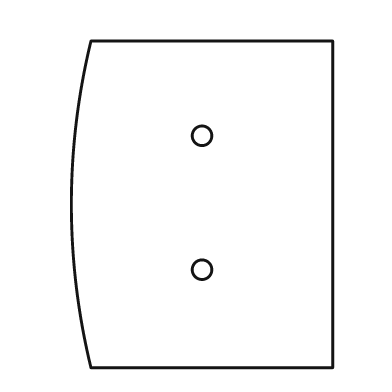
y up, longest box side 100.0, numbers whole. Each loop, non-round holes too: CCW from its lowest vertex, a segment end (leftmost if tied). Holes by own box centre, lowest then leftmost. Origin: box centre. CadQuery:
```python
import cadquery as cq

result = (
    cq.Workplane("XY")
    .moveTo(-34.0, -50.0)
    .lineTo(40.0, -50.0)
    .lineTo(40.0, 50.0)
    .lineTo(-34.0, 50.0)
    .threePointArc((-40.0, 0.0), (-34.0, -50.0))
    .close()
    .moveTo(0.0, -20.0)
    .circle(3.0)
    .moveTo(0.0, 21.0)
    .circle(3.0)
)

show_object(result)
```